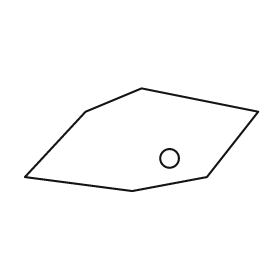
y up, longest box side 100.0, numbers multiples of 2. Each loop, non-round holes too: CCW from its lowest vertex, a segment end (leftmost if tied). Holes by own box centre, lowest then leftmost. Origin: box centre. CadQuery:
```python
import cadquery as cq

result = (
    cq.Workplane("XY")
    .moveTo(-4.0, -22.0)
    .lineTo(28.0, -16.0)
    .lineTo(50.0, 12.0)
    .lineTo(0.0, 22.0)
    .lineTo(-24.0, 12.0)
    .lineTo(-50.0, -16.0)
    .close()
    .moveTo(12.0, -8.0)
    .circle(4.0)
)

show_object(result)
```